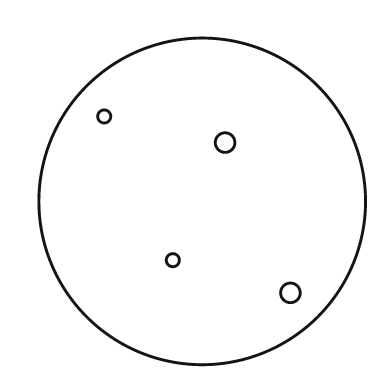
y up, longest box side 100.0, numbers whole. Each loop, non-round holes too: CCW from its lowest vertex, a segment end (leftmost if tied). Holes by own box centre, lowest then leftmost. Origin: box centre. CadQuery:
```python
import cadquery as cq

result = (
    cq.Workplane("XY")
    .moveTo(0.0, 0.0)
    .circle(50.0)
    .moveTo(27.0, -28.0)
    .circle(3.0)
    .moveTo(-9.0, -18.0)
    .circle(2.0)
    .moveTo(7.0, 18.0)
    .circle(3.0)
    .moveTo(-30.0, 26.0)
    .circle(2.0)
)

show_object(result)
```